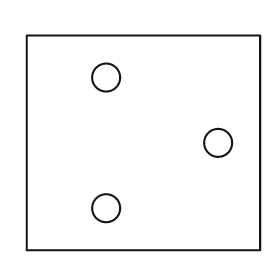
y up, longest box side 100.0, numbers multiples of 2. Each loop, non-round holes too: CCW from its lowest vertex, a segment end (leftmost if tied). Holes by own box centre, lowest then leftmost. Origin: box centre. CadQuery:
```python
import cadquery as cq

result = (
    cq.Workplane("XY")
    .moveTo(-50.0, -46.0)
    .lineTo(50.0, -46.0)
    .lineTo(50.0, 46.0)
    .lineTo(-50.0, 46.0)
    .close()
    .moveTo(-16.0, -28.0)
    .circle(6.0)
    .moveTo(32.0, 0.0)
    .circle(6.0)
    .moveTo(-16.0, 28.0)
    .circle(6.0)
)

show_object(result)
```